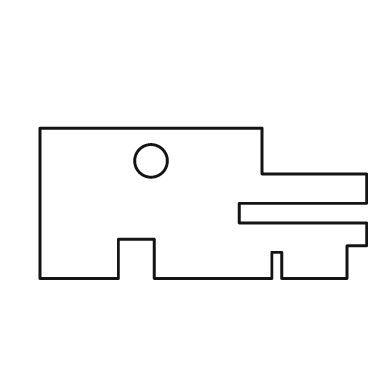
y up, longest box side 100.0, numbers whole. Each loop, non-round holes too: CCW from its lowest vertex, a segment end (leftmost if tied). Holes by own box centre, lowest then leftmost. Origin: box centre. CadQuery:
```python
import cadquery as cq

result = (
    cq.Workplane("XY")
    .moveTo(-50.0, -23.0)
    .lineTo(-26.0, -23.0)
    .lineTo(-26.0, -11.0)
    .lineTo(-15.0, -11.0)
    .lineTo(-15.0, -23.0)
    .lineTo(21.0, -23.0)
    .lineTo(21.0, -15.0)
    .lineTo(24.0, -15.0)
    .lineTo(24.0, -23.0)
    .lineTo(44.0, -23.0)
    .lineTo(44.0, -13.0)
    .lineTo(50.0, -13.0)
    .lineTo(50.0, -6.0)
    .lineTo(11.0, -6.0)
    .lineTo(11.0, 0.0)
    .lineTo(50.0, 0.0)
    .lineTo(50.0, 9.0)
    .lineTo(18.0, 9.0)
    .lineTo(18.0, 23.0)
    .lineTo(-50.0, 23.0)
    .close()
    .moveTo(-16.0, 13.0)
    .circle(5.0)
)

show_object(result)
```